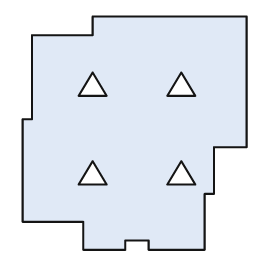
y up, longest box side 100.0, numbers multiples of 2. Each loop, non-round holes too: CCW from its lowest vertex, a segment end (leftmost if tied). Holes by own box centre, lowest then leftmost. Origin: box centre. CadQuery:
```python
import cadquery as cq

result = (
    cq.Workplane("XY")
    .moveTo(-22.0, -50.0)
    .lineTo(-4.0, -50.0)
    .lineTo(-4.0, -46.0)
    .lineTo(6.0, -46.0)
    .lineTo(6.0, -50.0)
    .lineTo(30.0, -50.0)
    .lineTo(30.0, -26.0)
    .lineTo(34.0, -26.0)
    .lineTo(34.0, -6.0)
    .lineTo(48.0, -6.0)
    .lineTo(48.0, 50.0)
    .lineTo(-18.0, 50.0)
    .lineTo(-18.0, 42.0)
    .lineTo(-44.0, 42.0)
    .lineTo(-44.0, 6.0)
    .lineTo(-48.0, 6.0)
    .lineTo(-48.0, -38.0)
    .lineTo(-22.0, -38.0)
    .close()
    .moveTo(-24.0, -22.0)
    .lineTo(-12.0, -22.0)
    .lineTo(-18.0, -12.0)
    .close()
    .moveTo(14.0, -22.0)
    .lineTo(26.0, -22.0)
    .lineTo(20.0, -12.0)
    .close()
    .moveTo(-24.0, 16.0)
    .lineTo(-12.0, 16.0)
    .lineTo(-18.0, 26.0)
    .close()
    .moveTo(14.0, 16.0)
    .lineTo(26.0, 16.0)
    .lineTo(20.0, 26.0)
    .close()
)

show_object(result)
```